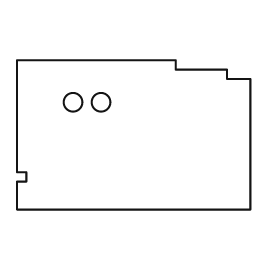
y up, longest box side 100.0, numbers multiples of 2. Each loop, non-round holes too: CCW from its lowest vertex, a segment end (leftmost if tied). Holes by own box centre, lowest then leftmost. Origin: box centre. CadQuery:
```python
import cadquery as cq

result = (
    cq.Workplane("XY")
    .moveTo(-50.0, -32.0)
    .lineTo(50.0, -32.0)
    .lineTo(50.0, 24.0)
    .lineTo(40.0, 24.0)
    .lineTo(40.0, 28.0)
    .lineTo(18.0, 28.0)
    .lineTo(18.0, 32.0)
    .lineTo(-50.0, 32.0)
    .lineTo(-50.0, -16.0)
    .lineTo(-46.0, -16.0)
    .lineTo(-46.0, -20.0)
    .lineTo(-50.0, -20.0)
    .close()
    .moveTo(-26.0, 14.0)
    .circle(4.0)
    .moveTo(-14.0, 14.0)
    .circle(4.0)
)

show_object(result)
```